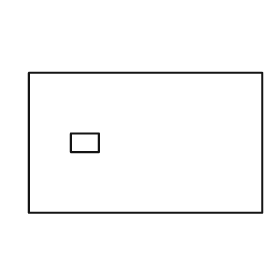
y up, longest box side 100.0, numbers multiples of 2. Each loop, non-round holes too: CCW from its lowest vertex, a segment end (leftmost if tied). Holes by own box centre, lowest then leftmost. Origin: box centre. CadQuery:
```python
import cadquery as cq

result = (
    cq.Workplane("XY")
    .moveTo(-50.0, -30.0)
    .lineTo(50.0, -30.0)
    .lineTo(50.0, 30.0)
    .lineTo(-50.0, 30.0)
    .close()
    .moveTo(-32.0, -4.0)
    .lineTo(-20.0, -4.0)
    .lineTo(-20.0, 4.0)
    .lineTo(-32.0, 4.0)
    .close()
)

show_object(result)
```